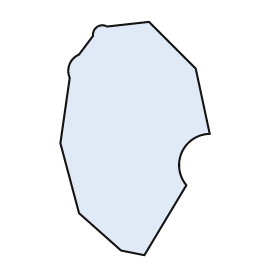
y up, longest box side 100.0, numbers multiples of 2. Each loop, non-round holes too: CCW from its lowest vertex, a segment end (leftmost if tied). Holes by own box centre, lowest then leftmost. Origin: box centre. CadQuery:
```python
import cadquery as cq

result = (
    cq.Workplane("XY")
    .moveTo(4.0, -50.0)
    .lineTo(22.0, -20.0)
    .threePointArc((20.0, -6.0), (32.0, 2.0))
    .lineTo(26.0, 30.0)
    .lineTo(6.0, 50.0)
    .lineTo(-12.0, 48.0)
    .threePointArc((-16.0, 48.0), (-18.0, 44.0))
    .lineTo(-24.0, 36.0)
    .threePointArc((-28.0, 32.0), (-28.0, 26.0))
    .lineTo(-32.0, -2.0)
    .lineTo(-24.0, -32.0)
    .lineTo(-6.0, -48.0)
    .close()
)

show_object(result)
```